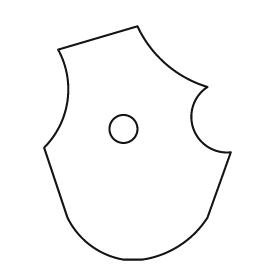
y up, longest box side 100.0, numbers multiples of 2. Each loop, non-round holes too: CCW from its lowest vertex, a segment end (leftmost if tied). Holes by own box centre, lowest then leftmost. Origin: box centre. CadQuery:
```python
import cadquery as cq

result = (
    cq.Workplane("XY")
    .moveTo(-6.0, -50.0)
    .lineTo(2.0, -50.0)
    .threePointArc((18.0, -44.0), (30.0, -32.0))
    .lineTo(40.0, -4.0)
    .threePointArc((24.0, 6.0), (30.0, 24.0))
    .threePointArc((12.0, 34.0), (0.0, 50.0))
    .lineTo(-34.0, 40.0)
    .threePointArc((-30.0, 18.0), (-40.0, -2.0))
    .lineTo(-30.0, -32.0)
    .threePointArc((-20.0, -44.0), (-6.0, -50.0))
    .close()
    .moveTo(-6.0, 6.0)
    .circle(6.0)
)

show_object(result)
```